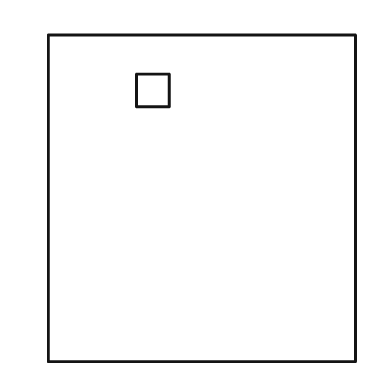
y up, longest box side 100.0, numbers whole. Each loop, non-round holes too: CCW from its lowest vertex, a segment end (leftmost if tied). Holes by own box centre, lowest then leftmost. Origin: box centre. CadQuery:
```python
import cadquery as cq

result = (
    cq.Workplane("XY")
    .moveTo(-47.0, -50.0)
    .lineTo(47.0, -50.0)
    .lineTo(47.0, 50.0)
    .lineTo(-47.0, 50.0)
    .close()
    .moveTo(-20.0, 28.0)
    .lineTo(-10.0, 28.0)
    .lineTo(-10.0, 38.0)
    .lineTo(-20.0, 38.0)
    .close()
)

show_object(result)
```